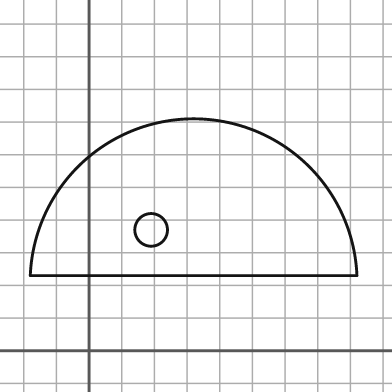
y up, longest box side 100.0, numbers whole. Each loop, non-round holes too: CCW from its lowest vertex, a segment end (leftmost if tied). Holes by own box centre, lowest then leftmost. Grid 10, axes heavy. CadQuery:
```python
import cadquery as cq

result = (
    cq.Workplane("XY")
    .moveTo(-18.0, 23.0)
    .lineTo(82.0, 23.0)
    .threePointArc((32.0, 71.0), (-18.0, 23.0))
    .close()
    .moveTo(19.0, 37.0)
    .circle(5.0)
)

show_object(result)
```